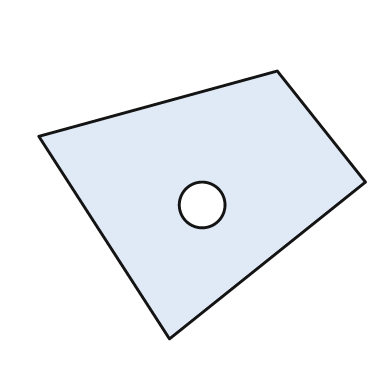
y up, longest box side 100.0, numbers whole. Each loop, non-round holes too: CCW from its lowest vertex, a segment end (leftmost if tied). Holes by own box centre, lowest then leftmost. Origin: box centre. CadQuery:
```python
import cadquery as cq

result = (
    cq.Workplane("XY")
    .moveTo(-10.0, -41.0)
    .lineTo(50.0, 7.0)
    .lineTo(23.0, 41.0)
    .lineTo(-50.0, 21.0)
    .close()
    .moveTo(0.0, 0.0)
    .circle(7.0)
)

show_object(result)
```